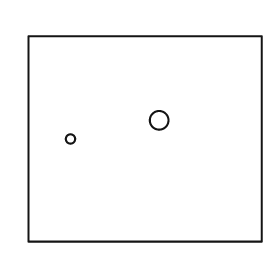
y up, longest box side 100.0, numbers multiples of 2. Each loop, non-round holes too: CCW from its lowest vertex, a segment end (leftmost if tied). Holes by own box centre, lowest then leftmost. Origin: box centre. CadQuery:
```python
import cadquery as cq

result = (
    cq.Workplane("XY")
    .moveTo(-50.0, -44.0)
    .lineTo(50.0, -44.0)
    .lineTo(50.0, 44.0)
    .lineTo(-50.0, 44.0)
    .close()
    .moveTo(-32.0, 0.0)
    .circle(2.0)
    .moveTo(6.0, 8.0)
    .circle(4.0)
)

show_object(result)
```